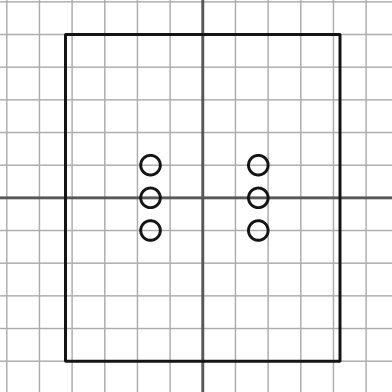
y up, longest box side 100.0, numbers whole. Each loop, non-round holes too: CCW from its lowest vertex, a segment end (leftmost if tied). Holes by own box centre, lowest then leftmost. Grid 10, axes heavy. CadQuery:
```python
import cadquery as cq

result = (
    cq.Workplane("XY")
    .moveTo(-42.0, -50.0)
    .lineTo(42.0, -50.0)
    .lineTo(42.0, 50.0)
    .lineTo(-42.0, 50.0)
    .close()
    .moveTo(-16.0, -10.0)
    .circle(3.0)
    .moveTo(17.0, -10.0)
    .circle(3.0)
    .moveTo(-16.0, 0.0)
    .circle(3.0)
    .moveTo(17.0, 0.0)
    .circle(3.0)
    .moveTo(-16.0, 10.0)
    .circle(3.0)
    .moveTo(17.0, 10.0)
    .circle(3.0)
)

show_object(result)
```